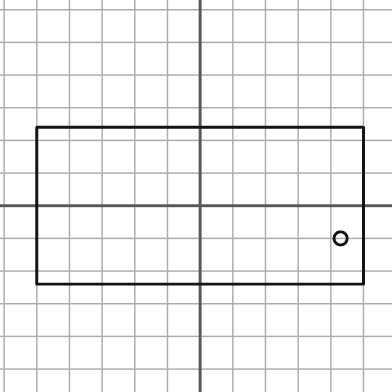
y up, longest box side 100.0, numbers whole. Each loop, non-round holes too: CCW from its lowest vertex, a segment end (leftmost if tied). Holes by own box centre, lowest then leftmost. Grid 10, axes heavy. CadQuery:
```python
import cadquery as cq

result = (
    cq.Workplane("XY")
    .moveTo(-50.0, -24.0)
    .lineTo(50.0, -24.0)
    .lineTo(50.0, 24.0)
    .lineTo(-50.0, 24.0)
    .close()
    .moveTo(43.0, -10.0)
    .circle(2.0)
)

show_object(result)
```